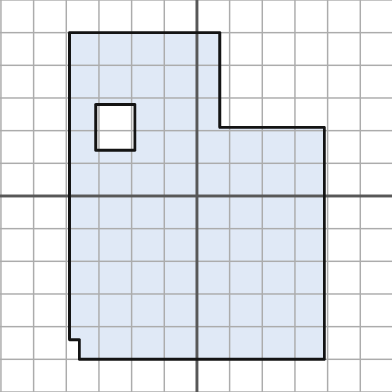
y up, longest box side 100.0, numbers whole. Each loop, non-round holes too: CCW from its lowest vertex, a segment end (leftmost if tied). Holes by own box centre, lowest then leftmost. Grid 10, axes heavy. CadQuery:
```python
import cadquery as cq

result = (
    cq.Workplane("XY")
    .moveTo(-36.0, -50.0)
    .lineTo(39.0, -50.0)
    .lineTo(39.0, 21.0)
    .lineTo(7.0, 21.0)
    .lineTo(7.0, 50.0)
    .lineTo(-39.0, 50.0)
    .lineTo(-39.0, -44.0)
    .lineTo(-36.0, -44.0)
    .close()
    .moveTo(-31.0, 14.0)
    .lineTo(-19.0, 14.0)
    .lineTo(-19.0, 28.0)
    .lineTo(-31.0, 28.0)
    .close()
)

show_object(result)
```